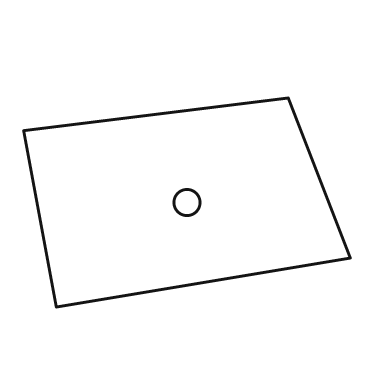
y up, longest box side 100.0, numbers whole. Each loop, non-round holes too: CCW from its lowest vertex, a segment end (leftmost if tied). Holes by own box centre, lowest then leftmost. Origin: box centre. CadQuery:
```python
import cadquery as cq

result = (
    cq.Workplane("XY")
    .moveTo(-40.0, -32.0)
    .lineTo(50.0, -17.0)
    .lineTo(31.0, 32.0)
    .lineTo(-50.0, 22.0)
    .close()
    .moveTo(0.0, 0.0)
    .circle(4.0)
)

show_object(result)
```